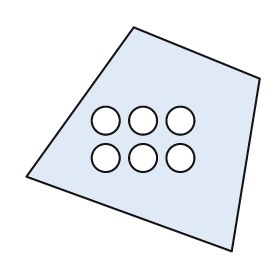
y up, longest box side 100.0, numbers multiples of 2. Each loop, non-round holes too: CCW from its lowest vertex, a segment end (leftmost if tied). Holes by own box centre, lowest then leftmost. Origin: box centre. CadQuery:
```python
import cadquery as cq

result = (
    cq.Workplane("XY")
    .moveTo(38.0, -48.0)
    .lineTo(50.0, 26.0)
    .lineTo(-4.0, 48.0)
    .lineTo(-50.0, -16.0)
    .close()
    .moveTo(-16.0, -8.0)
    .circle(6.0)
    .moveTo(0.0, -8.0)
    .circle(6.0)
    .moveTo(16.0, -8.0)
    .circle(6.0)
    .moveTo(-16.0, 8.0)
    .circle(6.0)
    .moveTo(0.0, 8.0)
    .circle(6.0)
    .moveTo(16.0, 8.0)
    .circle(6.0)
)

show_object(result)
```